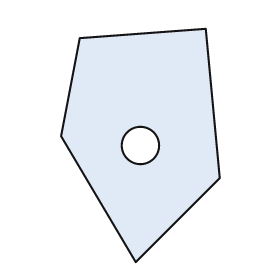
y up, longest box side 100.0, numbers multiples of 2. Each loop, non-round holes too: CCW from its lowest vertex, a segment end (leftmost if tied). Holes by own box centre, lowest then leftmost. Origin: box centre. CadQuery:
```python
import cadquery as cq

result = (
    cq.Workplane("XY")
    .moveTo(-2.0, -50.0)
    .lineTo(34.0, -14.0)
    .lineTo(28.0, 50.0)
    .lineTo(-26.0, 46.0)
    .lineTo(-34.0, 4.0)
    .close()
    .moveTo(0.0, 0.0)
    .circle(8.0)
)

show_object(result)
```